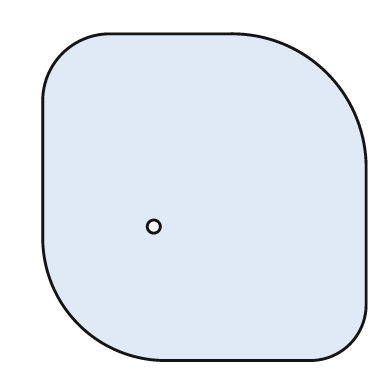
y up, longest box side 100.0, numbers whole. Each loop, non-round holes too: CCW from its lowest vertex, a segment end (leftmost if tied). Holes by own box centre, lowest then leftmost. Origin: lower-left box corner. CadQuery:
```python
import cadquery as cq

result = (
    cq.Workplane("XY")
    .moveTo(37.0, 0.0)
    .lineTo(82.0, 0.0)
    .threePointArc((94.0, 5.0), (99.0, 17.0))
    .lineTo(99.0, 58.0)
    .threePointArc((87.0, 88.0), (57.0, 100.0))
    .lineTo(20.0, 100.0)
    .threePointArc((6.0, 94.0), (0.0, 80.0))
    .lineTo(0.0, 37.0)
    .threePointArc((11.0, 11.0), (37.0, 0.0))
    .close()
    .moveTo(34.0, 41.0)
    .circle(2.0)
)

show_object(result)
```